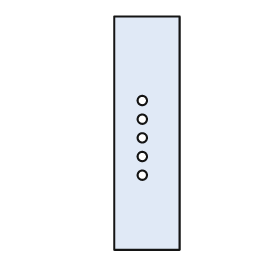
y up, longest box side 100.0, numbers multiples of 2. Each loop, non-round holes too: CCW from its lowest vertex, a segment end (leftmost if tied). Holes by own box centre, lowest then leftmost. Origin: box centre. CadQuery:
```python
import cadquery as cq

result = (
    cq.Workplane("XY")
    .moveTo(-14.0, -50.0)
    .lineTo(14.0, -50.0)
    .lineTo(14.0, 50.0)
    .lineTo(-14.0, 50.0)
    .close()
    .moveTo(-2.0, -18.0)
    .circle(2.0)
    .moveTo(-2.0, -10.0)
    .circle(2.0)
    .moveTo(-2.0, -2.0)
    .circle(2.0)
    .moveTo(-2.0, 6.0)
    .circle(2.0)
    .moveTo(-2.0, 14.0)
    .circle(2.0)
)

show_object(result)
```